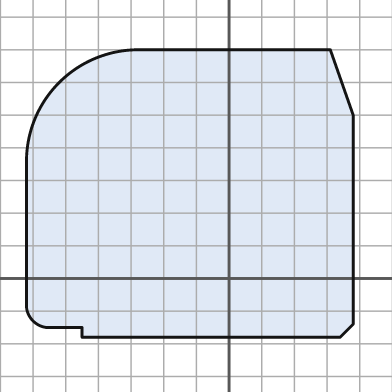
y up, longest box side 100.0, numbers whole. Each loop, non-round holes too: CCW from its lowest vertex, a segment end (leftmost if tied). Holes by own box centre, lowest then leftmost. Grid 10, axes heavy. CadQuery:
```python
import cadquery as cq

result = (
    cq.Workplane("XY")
    .moveTo(-45.0, -18.0)
    .lineTo(34.0, -18.0)
    .lineTo(38.0, -14.0)
    .lineTo(38.0, 50.0)
    .lineTo(31.0, 70.0)
    .lineTo(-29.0, 70.0)
    .threePointArc((-52.0, 60.0), (-62.0, 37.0))
    .lineTo(-62.0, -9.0)
    .threePointArc((-60.0, -13.0), (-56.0, -15.0))
    .lineTo(-45.0, -15.0)
    .close()
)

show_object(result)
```